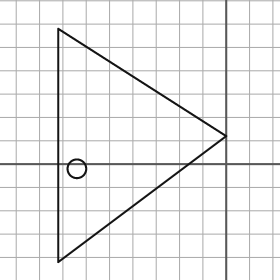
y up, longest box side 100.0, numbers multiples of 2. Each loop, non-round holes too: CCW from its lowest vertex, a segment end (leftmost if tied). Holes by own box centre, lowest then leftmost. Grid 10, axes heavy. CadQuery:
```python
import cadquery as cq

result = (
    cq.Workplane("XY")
    .moveTo(-72.0, -42.0)
    .lineTo(0.0, 12.0)
    .lineTo(-72.0, 58.0)
    .close()
    .moveTo(-64.0, -2.0)
    .circle(4.0)
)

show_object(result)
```